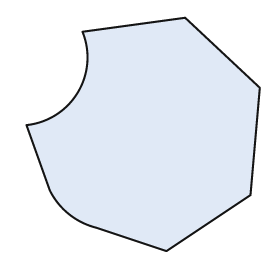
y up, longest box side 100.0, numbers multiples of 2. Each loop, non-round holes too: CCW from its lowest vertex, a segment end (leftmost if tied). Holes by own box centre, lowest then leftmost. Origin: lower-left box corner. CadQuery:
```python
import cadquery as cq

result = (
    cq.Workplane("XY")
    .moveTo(60.0, 0.0)
    .lineTo(96.0, 24.0)
    .lineTo(100.0, 70.0)
    .lineTo(68.0, 100.0)
    .lineTo(24.0, 94.0)
    .threePointArc((22.0, 68.0), (0.0, 54.0))
    .lineTo(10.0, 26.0)
    .threePointArc((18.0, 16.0), (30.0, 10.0))
    .close()
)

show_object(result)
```